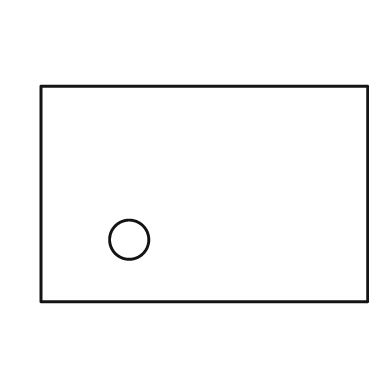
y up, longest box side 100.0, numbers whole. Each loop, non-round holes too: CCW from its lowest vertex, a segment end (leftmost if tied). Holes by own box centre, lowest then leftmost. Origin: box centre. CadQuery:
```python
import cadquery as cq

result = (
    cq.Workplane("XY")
    .moveTo(-50.0, -33.0)
    .lineTo(50.0, -33.0)
    .lineTo(50.0, 33.0)
    .lineTo(-50.0, 33.0)
    .close()
    .moveTo(-23.0, -14.0)
    .circle(6.0)
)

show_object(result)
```